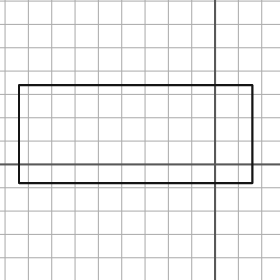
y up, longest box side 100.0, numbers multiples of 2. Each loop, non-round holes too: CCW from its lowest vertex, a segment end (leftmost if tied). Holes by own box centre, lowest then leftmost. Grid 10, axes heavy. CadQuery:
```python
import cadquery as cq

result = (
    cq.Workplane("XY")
    .moveTo(-84.0, -8.0)
    .lineTo(16.0, -8.0)
    .lineTo(16.0, 34.0)
    .lineTo(-84.0, 34.0)
    .close()
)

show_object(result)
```